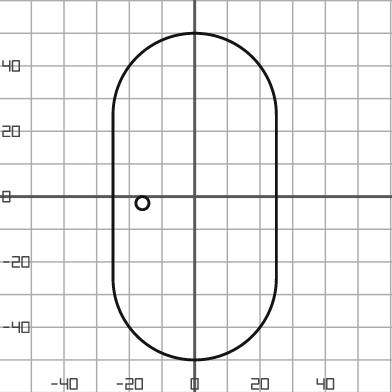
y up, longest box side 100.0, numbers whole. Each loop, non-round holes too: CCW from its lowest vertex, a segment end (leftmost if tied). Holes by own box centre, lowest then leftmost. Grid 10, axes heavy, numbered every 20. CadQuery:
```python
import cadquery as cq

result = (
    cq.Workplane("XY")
    .moveTo(-25.0, -25.0)
    .threePointArc((0.0, -50.0), (25.0, -25.0))
    .lineTo(25.0, 25.0)
    .threePointArc((0.0, 50.0), (-25.0, 25.0))
    .close()
    .moveTo(-16.0, -2.0)
    .circle(2.0)
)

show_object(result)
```